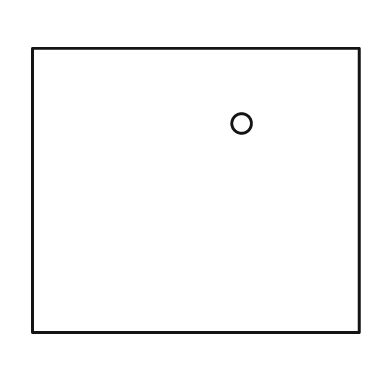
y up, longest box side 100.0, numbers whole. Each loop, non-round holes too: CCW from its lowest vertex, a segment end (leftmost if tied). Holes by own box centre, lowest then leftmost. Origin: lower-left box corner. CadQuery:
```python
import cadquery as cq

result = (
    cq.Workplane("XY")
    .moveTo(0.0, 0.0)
    .lineTo(100.0, 0.0)
    .lineTo(100.0, 87.0)
    .lineTo(0.0, 87.0)
    .close()
    .moveTo(64.0, 64.0)
    .circle(3.0)
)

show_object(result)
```